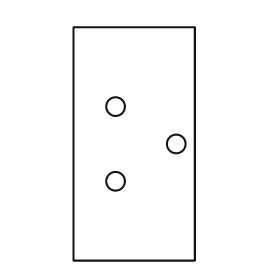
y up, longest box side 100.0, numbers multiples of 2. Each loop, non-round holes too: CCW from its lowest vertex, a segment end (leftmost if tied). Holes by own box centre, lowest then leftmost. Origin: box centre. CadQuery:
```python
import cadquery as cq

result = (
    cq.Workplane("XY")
    .moveTo(-26.0, -50.0)
    .lineTo(26.0, -50.0)
    .lineTo(26.0, 50.0)
    .lineTo(-26.0, 50.0)
    .close()
    .moveTo(-8.0, -16.0)
    .circle(4.0)
    .moveTo(18.0, 0.0)
    .circle(4.0)
    .moveTo(-8.0, 16.0)
    .circle(4.0)
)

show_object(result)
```